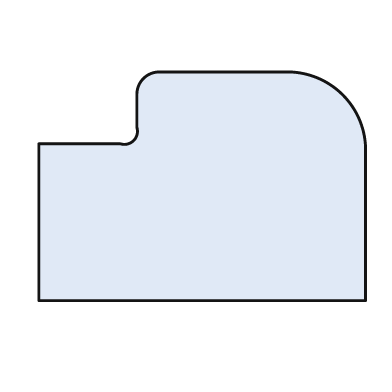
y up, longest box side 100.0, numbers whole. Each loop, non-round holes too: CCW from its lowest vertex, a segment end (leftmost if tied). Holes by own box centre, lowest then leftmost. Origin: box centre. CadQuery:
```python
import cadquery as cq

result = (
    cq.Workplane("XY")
    .moveTo(-50.0, -35.0)
    .lineTo(50.0, -35.0)
    .lineTo(50.0, 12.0)
    .threePointArc((43.0, 28.0), (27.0, 35.0))
    .lineTo(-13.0, 35.0)
    .threePointArc((-18.0, 33.0), (-20.0, 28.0))
    .lineTo(-20.0, 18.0)
    .threePointArc((-21.0, 14.0), (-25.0, 13.0))
    .lineTo(-50.0, 13.0)
    .close()
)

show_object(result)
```